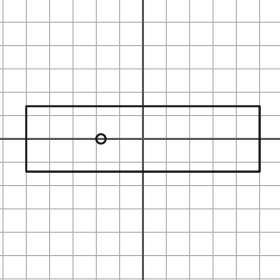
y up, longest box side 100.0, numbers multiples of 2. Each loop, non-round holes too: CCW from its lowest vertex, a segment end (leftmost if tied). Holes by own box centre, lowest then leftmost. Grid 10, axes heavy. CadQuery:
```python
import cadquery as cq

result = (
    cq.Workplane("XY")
    .moveTo(-50.0, -14.0)
    .lineTo(50.0, -14.0)
    .lineTo(50.0, 14.0)
    .lineTo(-50.0, 14.0)
    .close()
    .moveTo(-18.0, 0.0)
    .circle(2.0)
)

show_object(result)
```